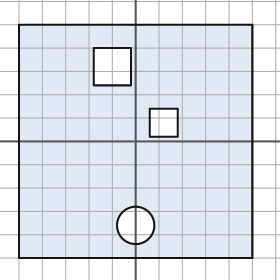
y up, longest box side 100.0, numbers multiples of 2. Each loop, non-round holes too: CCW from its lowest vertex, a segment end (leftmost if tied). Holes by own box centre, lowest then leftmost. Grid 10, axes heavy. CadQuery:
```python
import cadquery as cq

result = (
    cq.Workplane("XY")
    .moveTo(-50.0, -50.0)
    .lineTo(50.0, -50.0)
    .lineTo(50.0, 50.0)
    .lineTo(-50.0, 50.0)
    .close()
    .moveTo(0.0, -36.0)
    .circle(8.0)
    .moveTo(6.0, 2.0)
    .lineTo(18.0, 2.0)
    .lineTo(18.0, 14.0)
    .lineTo(6.0, 14.0)
    .close()
    .moveTo(-18.0, 24.0)
    .lineTo(-2.0, 24.0)
    .lineTo(-2.0, 40.0)
    .lineTo(-18.0, 40.0)
    .close()
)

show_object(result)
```